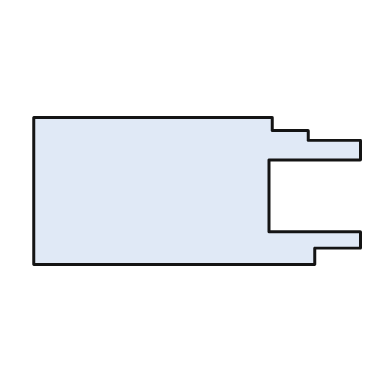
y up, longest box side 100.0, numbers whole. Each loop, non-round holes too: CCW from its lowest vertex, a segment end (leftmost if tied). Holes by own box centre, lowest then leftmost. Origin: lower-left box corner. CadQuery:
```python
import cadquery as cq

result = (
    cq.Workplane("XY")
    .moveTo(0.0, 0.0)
    .lineTo(86.0, 0.0)
    .lineTo(86.0, 5.0)
    .lineTo(100.0, 5.0)
    .lineTo(100.0, 10.0)
    .lineTo(72.0, 10.0)
    .lineTo(72.0, 32.0)
    .lineTo(100.0, 32.0)
    .lineTo(100.0, 38.0)
    .lineTo(84.0, 38.0)
    .lineTo(84.0, 41.0)
    .lineTo(73.0, 41.0)
    .lineTo(73.0, 45.0)
    .lineTo(0.0, 45.0)
    .close()
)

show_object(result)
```